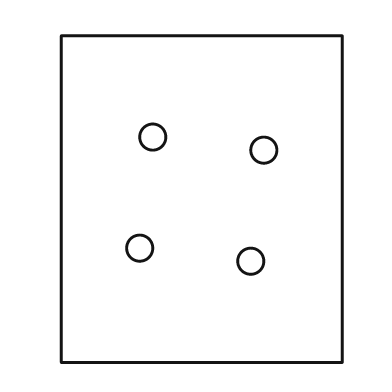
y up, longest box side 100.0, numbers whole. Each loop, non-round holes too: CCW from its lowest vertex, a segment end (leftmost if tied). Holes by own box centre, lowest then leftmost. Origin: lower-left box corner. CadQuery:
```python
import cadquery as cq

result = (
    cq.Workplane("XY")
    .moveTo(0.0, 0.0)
    .lineTo(86.0, 0.0)
    .lineTo(86.0, 100.0)
    .lineTo(0.0, 100.0)
    .close()
    .moveTo(58.0, 31.0)
    .circle(4.0)
    .moveTo(24.0, 35.0)
    .circle(4.0)
    .moveTo(62.0, 65.0)
    .circle(4.0)
    .moveTo(28.0, 69.0)
    .circle(4.0)
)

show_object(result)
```